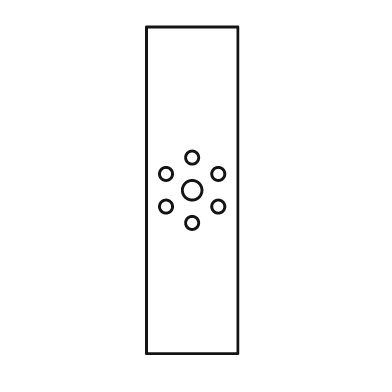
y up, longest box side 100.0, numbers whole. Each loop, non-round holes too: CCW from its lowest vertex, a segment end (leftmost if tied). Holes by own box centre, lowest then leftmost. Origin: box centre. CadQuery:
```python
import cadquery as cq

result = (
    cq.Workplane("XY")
    .moveTo(-14.0, -50.0)
    .lineTo(14.0, -50.0)
    .lineTo(14.0, 50.0)
    .lineTo(-14.0, 50.0)
    .close()
    .moveTo(0.0, -10.0)
    .circle(2.0)
    .moveTo(-8.0, -5.0)
    .circle(2.0)
    .moveTo(8.0, -5.0)
    .circle(2.0)
    .moveTo(0.0, 0.0)
    .circle(3.0)
    .moveTo(-8.0, 5.0)
    .circle(2.0)
    .moveTo(8.0, 5.0)
    .circle(2.0)
    .moveTo(0.0, 10.0)
    .circle(2.0)
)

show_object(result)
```